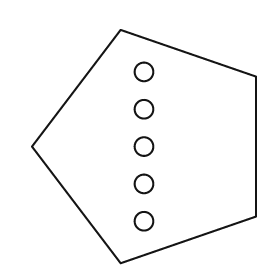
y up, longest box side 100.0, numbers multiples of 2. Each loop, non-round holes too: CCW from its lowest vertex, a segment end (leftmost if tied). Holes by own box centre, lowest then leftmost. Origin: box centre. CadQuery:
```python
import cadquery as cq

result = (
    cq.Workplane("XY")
    .moveTo(-10.0, -50.0)
    .lineTo(48.0, -30.0)
    .lineTo(48.0, 30.0)
    .lineTo(-10.0, 50.0)
    .lineTo(-48.0, 0.0)
    .close()
    .moveTo(0.0, -32.0)
    .circle(4.0)
    .moveTo(0.0, -16.0)
    .circle(4.0)
    .moveTo(0.0, 0.0)
    .circle(4.0)
    .moveTo(0.0, 16.0)
    .circle(4.0)
    .moveTo(0.0, 32.0)
    .circle(4.0)
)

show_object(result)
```